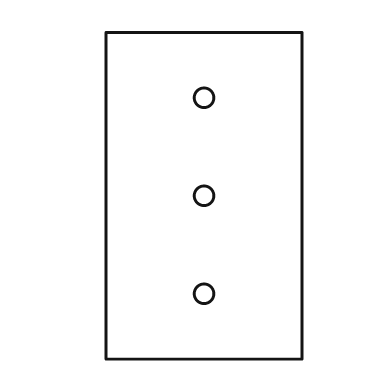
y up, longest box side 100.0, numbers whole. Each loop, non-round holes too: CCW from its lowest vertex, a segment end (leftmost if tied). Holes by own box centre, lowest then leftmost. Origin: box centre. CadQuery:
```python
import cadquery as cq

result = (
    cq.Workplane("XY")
    .moveTo(-30.0, -50.0)
    .lineTo(30.0, -50.0)
    .lineTo(30.0, 50.0)
    .lineTo(-30.0, 50.0)
    .close()
    .moveTo(0.0, -30.0)
    .circle(3.0)
    .moveTo(0.0, 0.0)
    .circle(3.0)
    .moveTo(0.0, 30.0)
    .circle(3.0)
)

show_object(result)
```